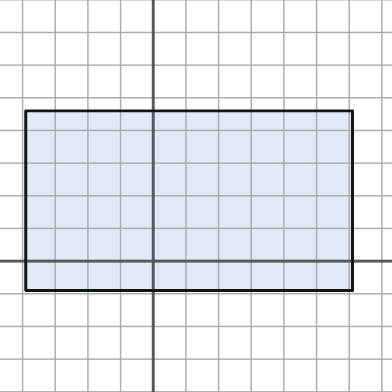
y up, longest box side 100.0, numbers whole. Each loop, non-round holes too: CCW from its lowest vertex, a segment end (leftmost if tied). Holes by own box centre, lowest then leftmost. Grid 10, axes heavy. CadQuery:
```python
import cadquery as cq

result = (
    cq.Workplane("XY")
    .moveTo(-39.0, -9.0)
    .lineTo(61.0, -9.0)
    .lineTo(61.0, 46.0)
    .lineTo(-39.0, 46.0)
    .close()
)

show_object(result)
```